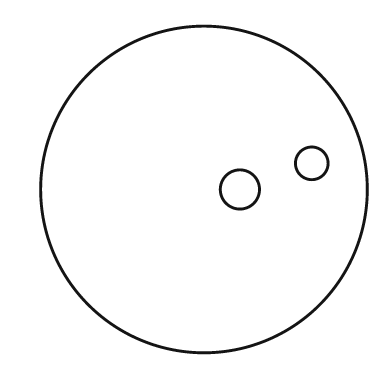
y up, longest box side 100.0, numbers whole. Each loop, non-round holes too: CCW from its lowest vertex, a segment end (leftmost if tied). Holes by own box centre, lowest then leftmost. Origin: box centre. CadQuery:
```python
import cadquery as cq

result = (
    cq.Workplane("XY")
    .moveTo(0.0, 0.0)
    .circle(50.0)
    .moveTo(11.0, 0.0)
    .circle(6.0)
    .moveTo(33.0, 8.0)
    .circle(5.0)
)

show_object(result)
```